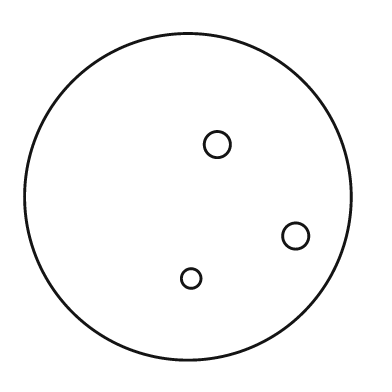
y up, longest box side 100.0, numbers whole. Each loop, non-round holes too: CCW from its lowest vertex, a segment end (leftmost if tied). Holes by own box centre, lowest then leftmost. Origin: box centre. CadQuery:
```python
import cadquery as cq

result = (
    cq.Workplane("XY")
    .moveTo(0.0, 0.0)
    .circle(50.0)
    .moveTo(1.0, -25.0)
    .circle(3.0)
    .moveTo(33.0, -12.0)
    .circle(4.0)
    .moveTo(9.0, 16.0)
    .circle(4.0)
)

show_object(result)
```